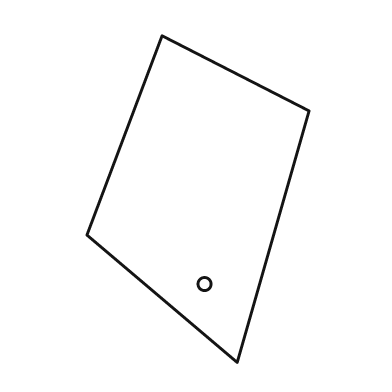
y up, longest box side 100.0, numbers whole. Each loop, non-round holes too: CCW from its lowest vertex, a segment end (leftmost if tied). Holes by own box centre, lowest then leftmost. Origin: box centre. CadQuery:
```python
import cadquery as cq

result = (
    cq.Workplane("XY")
    .moveTo(12.0, -50.0)
    .lineTo(34.0, 27.0)
    .lineTo(-11.0, 50.0)
    .lineTo(-34.0, -11.0)
    .close()
    .moveTo(2.0, -26.0)
    .circle(2.0)
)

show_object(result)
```